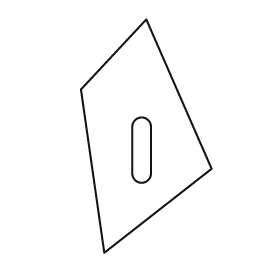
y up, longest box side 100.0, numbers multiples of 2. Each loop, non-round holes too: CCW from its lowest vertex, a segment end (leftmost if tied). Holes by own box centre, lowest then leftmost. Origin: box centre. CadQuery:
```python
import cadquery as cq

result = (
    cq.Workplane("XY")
    .moveTo(-18.0, -50.0)
    .lineTo(28.0, -14.0)
    .lineTo(0.0, 50.0)
    .lineTo(-28.0, 20.0)
    .close()
    .moveTo(-6.0, -16.0)
    .threePointArc((-2.0, -20.0), (2.0, -16.0))
    .lineTo(2.0, 4.0)
    .threePointArc((-2.0, 8.0), (-6.0, 4.0))
    .close()
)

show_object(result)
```